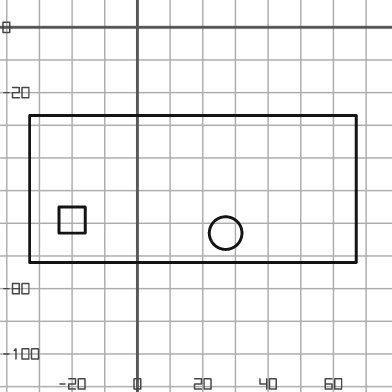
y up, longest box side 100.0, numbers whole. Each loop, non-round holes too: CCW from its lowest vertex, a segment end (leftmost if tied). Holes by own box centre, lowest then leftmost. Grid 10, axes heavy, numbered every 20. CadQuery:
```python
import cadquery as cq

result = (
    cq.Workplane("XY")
    .moveTo(-33.0, -72.0)
    .lineTo(67.0, -72.0)
    .lineTo(67.0, -27.0)
    .lineTo(-33.0, -27.0)
    .close()
    .moveTo(27.0, -63.0)
    .circle(5.0)
    .moveTo(-24.0, -63.0)
    .lineTo(-16.0, -63.0)
    .lineTo(-16.0, -55.0)
    .lineTo(-24.0, -55.0)
    .close()
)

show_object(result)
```